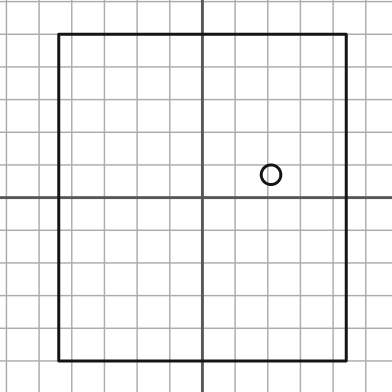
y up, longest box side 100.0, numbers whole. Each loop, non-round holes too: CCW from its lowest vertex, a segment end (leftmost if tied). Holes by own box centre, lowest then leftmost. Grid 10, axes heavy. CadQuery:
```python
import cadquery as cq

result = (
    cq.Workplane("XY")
    .moveTo(-44.0, -50.0)
    .lineTo(44.0, -50.0)
    .lineTo(44.0, 50.0)
    .lineTo(-44.0, 50.0)
    .close()
    .moveTo(21.0, 7.0)
    .circle(3.0)
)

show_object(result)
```